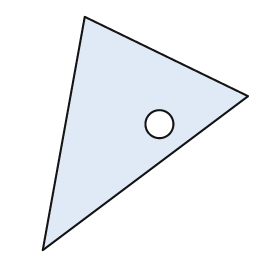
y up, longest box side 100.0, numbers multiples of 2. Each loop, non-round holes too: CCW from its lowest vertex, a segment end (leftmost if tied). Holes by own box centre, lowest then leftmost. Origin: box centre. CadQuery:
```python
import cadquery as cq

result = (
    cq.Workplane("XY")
    .moveTo(-44.0, -50.0)
    .lineTo(44.0, 16.0)
    .lineTo(-26.0, 50.0)
    .close()
    .moveTo(6.0, 4.0)
    .circle(6.0)
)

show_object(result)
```